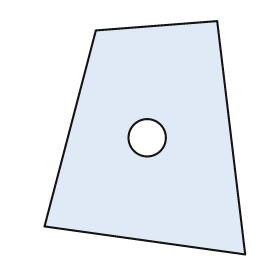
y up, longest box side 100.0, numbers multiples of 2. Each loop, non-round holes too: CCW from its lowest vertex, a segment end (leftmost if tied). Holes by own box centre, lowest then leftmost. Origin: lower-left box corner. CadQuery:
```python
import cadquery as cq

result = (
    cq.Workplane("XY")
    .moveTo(86.0, 0.0)
    .lineTo(74.0, 100.0)
    .lineTo(22.0, 96.0)
    .lineTo(0.0, 12.0)
    .close()
    .moveTo(44.0, 50.0)
    .circle(8.0)
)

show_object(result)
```